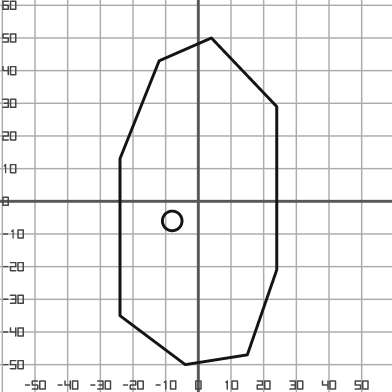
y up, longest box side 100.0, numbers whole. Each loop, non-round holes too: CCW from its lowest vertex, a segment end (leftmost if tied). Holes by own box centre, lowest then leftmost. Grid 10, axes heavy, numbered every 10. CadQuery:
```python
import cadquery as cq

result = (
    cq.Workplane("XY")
    .moveTo(-4.0, -50.0)
    .lineTo(15.0, -47.0)
    .lineTo(24.0, -21.0)
    .lineTo(24.0, 29.0)
    .lineTo(4.0, 50.0)
    .lineTo(-12.0, 43.0)
    .lineTo(-24.0, 13.0)
    .lineTo(-24.0, -35.0)
    .close()
    .moveTo(-8.0, -6.0)
    .circle(3.0)
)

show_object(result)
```